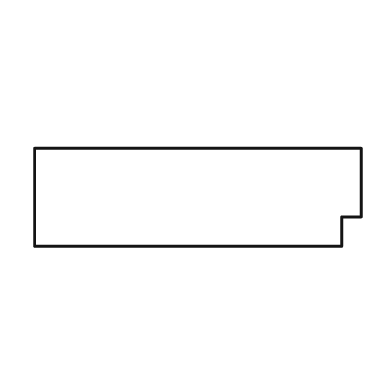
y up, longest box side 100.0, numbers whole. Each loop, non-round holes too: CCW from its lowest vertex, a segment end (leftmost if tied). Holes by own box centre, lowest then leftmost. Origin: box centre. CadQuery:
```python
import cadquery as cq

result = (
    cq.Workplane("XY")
    .moveTo(-50.0, -15.0)
    .lineTo(44.0, -15.0)
    .lineTo(44.0, -6.0)
    .lineTo(50.0, -6.0)
    .lineTo(50.0, 15.0)
    .lineTo(-50.0, 15.0)
    .close()
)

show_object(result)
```